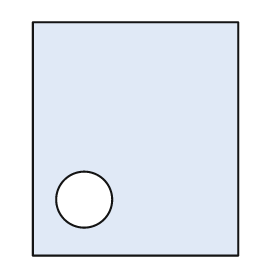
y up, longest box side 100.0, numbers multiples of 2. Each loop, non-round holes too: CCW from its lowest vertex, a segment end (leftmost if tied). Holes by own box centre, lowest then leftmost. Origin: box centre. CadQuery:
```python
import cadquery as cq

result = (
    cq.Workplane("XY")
    .moveTo(-44.0, -50.0)
    .lineTo(44.0, -50.0)
    .lineTo(44.0, 50.0)
    .lineTo(-44.0, 50.0)
    .close()
    .moveTo(-22.0, -26.0)
    .circle(12.0)
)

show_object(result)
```